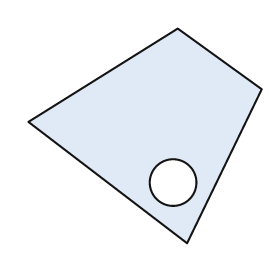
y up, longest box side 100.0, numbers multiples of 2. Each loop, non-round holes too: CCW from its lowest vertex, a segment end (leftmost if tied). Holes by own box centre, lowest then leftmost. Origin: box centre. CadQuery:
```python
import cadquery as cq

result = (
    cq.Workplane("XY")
    .moveTo(18.0, -46.0)
    .lineTo(50.0, 20.0)
    .lineTo(14.0, 46.0)
    .lineTo(-50.0, 6.0)
    .close()
    .moveTo(12.0, -20.0)
    .circle(10.0)
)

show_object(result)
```